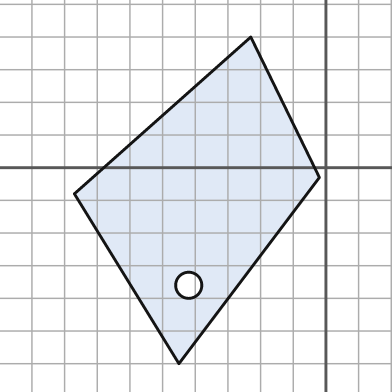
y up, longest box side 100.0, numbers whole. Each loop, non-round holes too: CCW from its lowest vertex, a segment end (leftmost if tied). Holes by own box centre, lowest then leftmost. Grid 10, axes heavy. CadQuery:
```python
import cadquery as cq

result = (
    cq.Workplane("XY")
    .moveTo(-45.0, -60.0)
    .lineTo(-2.0, -3.0)
    .lineTo(-23.0, 40.0)
    .lineTo(-77.0, -8.0)
    .close()
    .moveTo(-42.0, -36.0)
    .circle(4.0)
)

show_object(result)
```